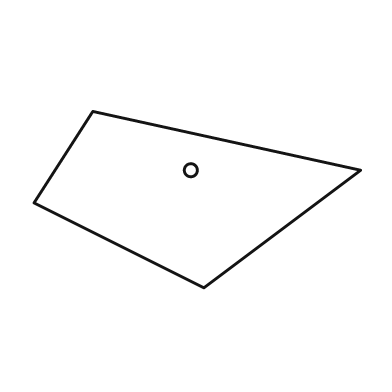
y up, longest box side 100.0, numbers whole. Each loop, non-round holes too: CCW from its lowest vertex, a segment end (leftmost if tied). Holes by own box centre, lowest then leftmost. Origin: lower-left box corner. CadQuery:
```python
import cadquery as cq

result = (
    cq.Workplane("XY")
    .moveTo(52.0, 0.0)
    .lineTo(100.0, 36.0)
    .lineTo(18.0, 54.0)
    .lineTo(0.0, 26.0)
    .close()
    .moveTo(48.0, 36.0)
    .circle(2.0)
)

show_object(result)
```